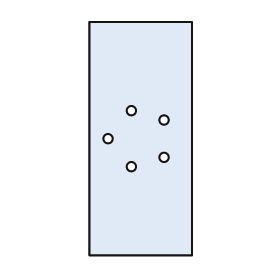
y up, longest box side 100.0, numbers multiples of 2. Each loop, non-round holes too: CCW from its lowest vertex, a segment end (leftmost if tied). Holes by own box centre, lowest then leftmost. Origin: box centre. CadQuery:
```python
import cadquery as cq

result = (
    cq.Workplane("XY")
    .moveTo(-22.0, -50.0)
    .lineTo(22.0, -50.0)
    .lineTo(22.0, 50.0)
    .lineTo(-22.0, 50.0)
    .close()
    .moveTo(-4.0, -12.0)
    .circle(2.0)
    .moveTo(10.0, -8.0)
    .circle(2.0)
    .moveTo(-14.0, 0.0)
    .circle(2.0)
    .moveTo(10.0, 8.0)
    .circle(2.0)
    .moveTo(-4.0, 12.0)
    .circle(2.0)
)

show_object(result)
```